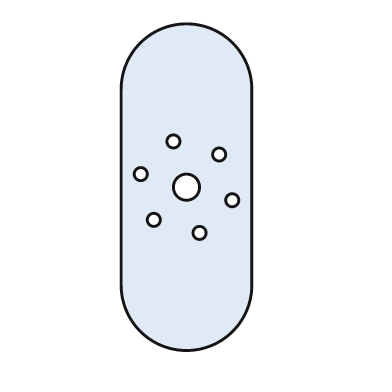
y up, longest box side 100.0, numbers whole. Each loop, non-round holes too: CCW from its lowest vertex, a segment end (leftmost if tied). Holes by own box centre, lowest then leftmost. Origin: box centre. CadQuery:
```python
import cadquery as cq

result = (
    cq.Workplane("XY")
    .moveTo(-20.0, -30.0)
    .threePointArc((0.0, -50.0), (20.0, -30.0))
    .lineTo(20.0, 30.0)
    .threePointArc((0.0, 50.0), (-20.0, 30.0))
    .close()
    .moveTo(4.0, -14.0)
    .circle(2.0)
    .moveTo(-10.0, -10.0)
    .circle(2.0)
    .moveTo(14.0, -4.0)
    .circle(2.0)
    .moveTo(0.0, 0.0)
    .circle(4.0)
    .moveTo(-14.0, 4.0)
    .circle(2.0)
    .moveTo(10.0, 10.0)
    .circle(2.0)
    .moveTo(-4.0, 14.0)
    .circle(2.0)
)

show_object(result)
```